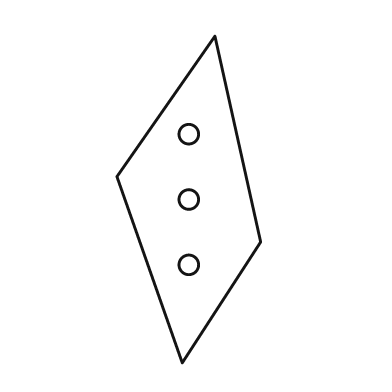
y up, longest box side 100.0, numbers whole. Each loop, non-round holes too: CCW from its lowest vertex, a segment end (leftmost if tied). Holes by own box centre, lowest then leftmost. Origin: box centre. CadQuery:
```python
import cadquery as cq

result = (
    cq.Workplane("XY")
    .moveTo(-2.0, -50.0)
    .lineTo(22.0, -13.0)
    .lineTo(8.0, 50.0)
    .lineTo(-22.0, 7.0)
    .close()
    .moveTo(0.0, -20.0)
    .circle(3.0)
    .moveTo(0.0, 0.0)
    .circle(3.0)
    .moveTo(0.0, 20.0)
    .circle(3.0)
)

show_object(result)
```